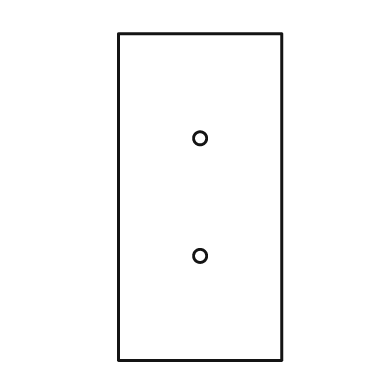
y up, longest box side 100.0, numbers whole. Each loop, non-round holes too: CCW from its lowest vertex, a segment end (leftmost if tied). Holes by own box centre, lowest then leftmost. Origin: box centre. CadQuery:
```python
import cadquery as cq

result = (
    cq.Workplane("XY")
    .moveTo(-25.0, -50.0)
    .lineTo(25.0, -50.0)
    .lineTo(25.0, 50.0)
    .lineTo(-25.0, 50.0)
    .close()
    .moveTo(0.0, -18.0)
    .circle(2.0)
    .moveTo(0.0, 18.0)
    .circle(2.0)
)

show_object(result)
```